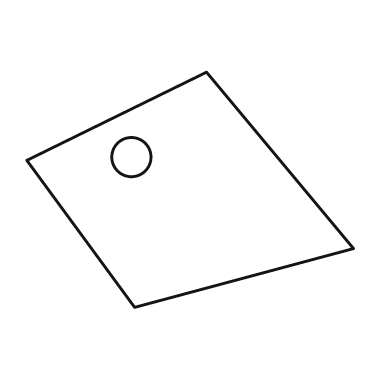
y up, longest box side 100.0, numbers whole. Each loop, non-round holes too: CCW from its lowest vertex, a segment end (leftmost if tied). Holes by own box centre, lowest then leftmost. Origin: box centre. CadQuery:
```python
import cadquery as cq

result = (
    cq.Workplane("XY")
    .moveTo(-17.0, -36.0)
    .lineTo(50.0, -18.0)
    .lineTo(5.0, 36.0)
    .lineTo(-50.0, 9.0)
    .close()
    .moveTo(-18.0, 10.0)
    .circle(6.0)
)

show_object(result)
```